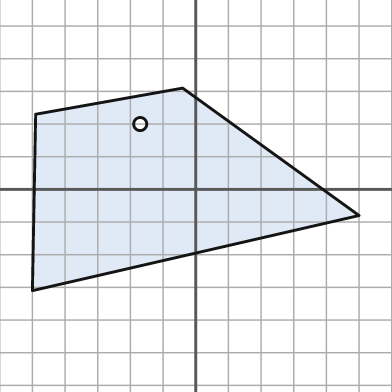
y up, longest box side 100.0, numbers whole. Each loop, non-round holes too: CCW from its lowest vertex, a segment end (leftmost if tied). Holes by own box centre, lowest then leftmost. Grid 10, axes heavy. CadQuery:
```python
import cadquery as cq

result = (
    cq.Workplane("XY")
    .moveTo(-50.0, -31.0)
    .lineTo(50.0, -8.0)
    .lineTo(-4.0, 31.0)
    .lineTo(-49.0, 23.0)
    .close()
    .moveTo(-17.0, 20.0)
    .circle(2.0)
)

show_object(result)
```